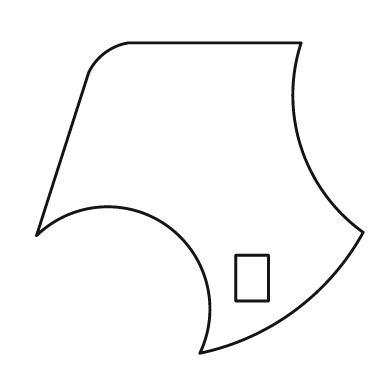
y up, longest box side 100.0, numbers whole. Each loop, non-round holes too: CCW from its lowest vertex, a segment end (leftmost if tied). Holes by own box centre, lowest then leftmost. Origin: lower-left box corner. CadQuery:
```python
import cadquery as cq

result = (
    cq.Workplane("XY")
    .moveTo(50.0, 0.0)
    .threePointArc((79.0, 13.0), (100.0, 37.0))
    .threePointArc((81.0, 63.0), (81.0, 95.0))
    .lineTo(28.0, 95.0)
    .threePointArc((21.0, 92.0), (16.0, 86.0))
    .lineTo(0.0, 36.0)
    .threePointArc((40.0, 39.0), (50.0, 0.0))
    .close()
    .moveTo(61.0, 16.0)
    .lineTo(71.0, 16.0)
    .lineTo(71.0, 30.0)
    .lineTo(61.0, 30.0)
    .close()
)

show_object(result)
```